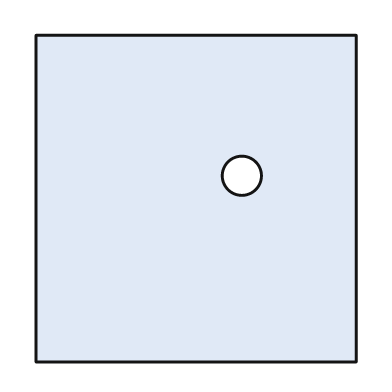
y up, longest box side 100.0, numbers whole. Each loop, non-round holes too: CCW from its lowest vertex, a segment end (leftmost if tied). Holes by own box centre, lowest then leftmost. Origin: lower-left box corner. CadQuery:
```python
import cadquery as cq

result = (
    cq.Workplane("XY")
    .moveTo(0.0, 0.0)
    .lineTo(98.0, 0.0)
    .lineTo(98.0, 100.0)
    .lineTo(0.0, 100.0)
    .close()
    .moveTo(63.0, 57.0)
    .circle(6.0)
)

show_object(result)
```